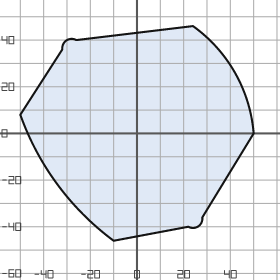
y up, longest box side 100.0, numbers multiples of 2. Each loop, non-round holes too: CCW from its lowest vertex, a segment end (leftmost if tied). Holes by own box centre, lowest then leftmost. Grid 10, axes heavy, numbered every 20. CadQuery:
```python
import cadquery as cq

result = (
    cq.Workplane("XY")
    .moveTo(-10.0, -46.0)
    .lineTo(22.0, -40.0)
    .threePointArc((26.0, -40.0), (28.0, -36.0))
    .lineTo(50.0, 0.0)
    .threePointArc((42.0, 26.0), (24.0, 46.0))
    .lineTo(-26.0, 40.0)
    .threePointArc((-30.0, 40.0), (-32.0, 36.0))
    .lineTo(-50.0, 8.0)
    .threePointArc((-34.0, -22.0), (-10.0, -46.0))
    .close()
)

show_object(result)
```